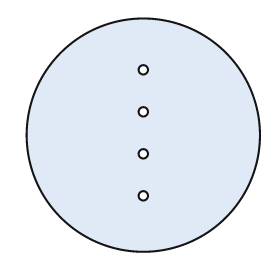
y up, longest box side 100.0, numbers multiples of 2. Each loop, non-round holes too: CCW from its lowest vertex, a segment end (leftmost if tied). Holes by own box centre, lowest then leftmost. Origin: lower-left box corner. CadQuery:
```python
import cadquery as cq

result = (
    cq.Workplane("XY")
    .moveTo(50.0, 50.0)
    .circle(50.0)
    .moveTo(50.0, 24.0)
    .circle(2.0)
    .moveTo(50.0, 42.0)
    .circle(2.0)
    .moveTo(50.0, 60.0)
    .circle(2.0)
    .moveTo(50.0, 78.0)
    .circle(2.0)
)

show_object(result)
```